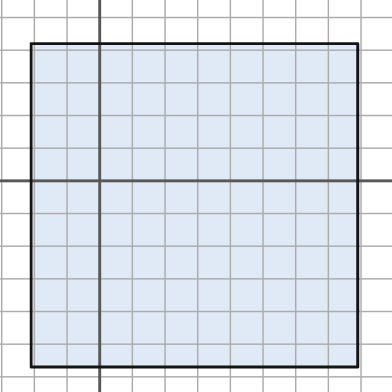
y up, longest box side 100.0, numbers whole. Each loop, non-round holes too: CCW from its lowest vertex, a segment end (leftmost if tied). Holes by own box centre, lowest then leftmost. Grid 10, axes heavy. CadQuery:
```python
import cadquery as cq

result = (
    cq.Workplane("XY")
    .moveTo(-21.0, -57.0)
    .lineTo(79.0, -57.0)
    .lineTo(79.0, 42.0)
    .lineTo(-21.0, 42.0)
    .close()
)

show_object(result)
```